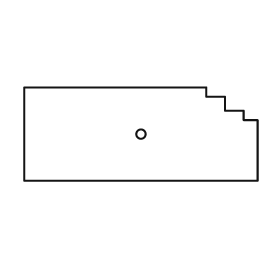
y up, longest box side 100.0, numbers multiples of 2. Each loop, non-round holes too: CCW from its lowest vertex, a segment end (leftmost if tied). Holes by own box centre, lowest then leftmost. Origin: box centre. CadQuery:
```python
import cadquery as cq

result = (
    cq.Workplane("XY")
    .moveTo(-50.0, -20.0)
    .lineTo(50.0, -20.0)
    .lineTo(50.0, 6.0)
    .lineTo(44.0, 6.0)
    .lineTo(44.0, 10.0)
    .lineTo(36.0, 10.0)
    .lineTo(36.0, 16.0)
    .lineTo(28.0, 16.0)
    .lineTo(28.0, 20.0)
    .lineTo(-50.0, 20.0)
    .close()
    .moveTo(0.0, 0.0)
    .circle(2.0)
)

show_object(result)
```